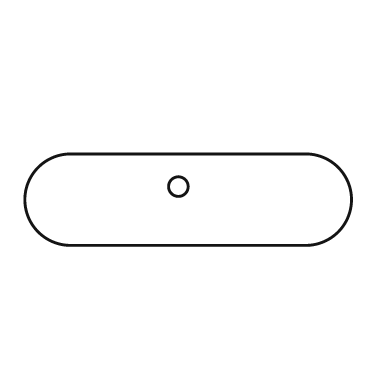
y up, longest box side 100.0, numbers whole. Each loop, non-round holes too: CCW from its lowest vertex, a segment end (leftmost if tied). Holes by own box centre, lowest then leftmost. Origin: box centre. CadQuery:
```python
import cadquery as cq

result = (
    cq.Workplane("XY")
    .moveTo(-36.0, -14.0)
    .lineTo(36.0, -14.0)
    .threePointArc((50.0, 0.0), (36.0, 14.0))
    .lineTo(-36.0, 14.0)
    .threePointArc((-50.0, 0.0), (-36.0, -14.0))
    .close()
    .moveTo(-3.0, 4.0)
    .circle(3.0)
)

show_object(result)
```